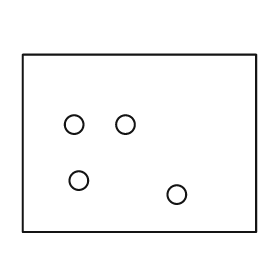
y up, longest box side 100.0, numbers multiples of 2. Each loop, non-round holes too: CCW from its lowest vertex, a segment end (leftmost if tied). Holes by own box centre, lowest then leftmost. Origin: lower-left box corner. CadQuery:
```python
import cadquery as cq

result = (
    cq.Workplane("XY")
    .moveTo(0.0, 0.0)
    .lineTo(100.0, 0.0)
    .lineTo(100.0, 76.0)
    .lineTo(0.0, 76.0)
    .close()
    .moveTo(66.0, 16.0)
    .circle(4.0)
    .moveTo(24.0, 22.0)
    .circle(4.0)
    .moveTo(22.0, 46.0)
    .circle(4.0)
    .moveTo(44.0, 46.0)
    .circle(4.0)
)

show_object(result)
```